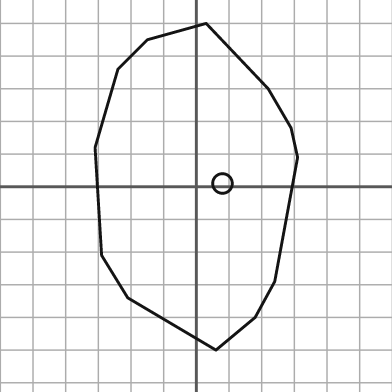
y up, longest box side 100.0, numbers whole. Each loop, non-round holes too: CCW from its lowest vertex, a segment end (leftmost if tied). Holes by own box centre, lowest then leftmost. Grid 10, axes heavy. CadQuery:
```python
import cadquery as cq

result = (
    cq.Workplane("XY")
    .moveTo(6.0, -50.0)
    .lineTo(18.0, -40.0)
    .lineTo(24.0, -29.0)
    .lineTo(31.0, 9.0)
    .lineTo(29.0, 18.0)
    .lineTo(22.0, 30.0)
    .lineTo(3.0, 50.0)
    .lineTo(-15.0, 45.0)
    .lineTo(-24.0, 36.0)
    .lineTo(-31.0, 12.0)
    .lineTo(-29.0, -21.0)
    .lineTo(-21.0, -34.0)
    .close()
    .moveTo(8.0, 1.0)
    .circle(3.0)
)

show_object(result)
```